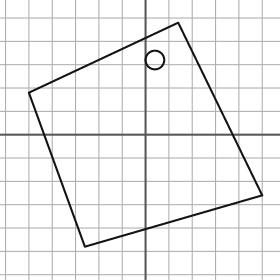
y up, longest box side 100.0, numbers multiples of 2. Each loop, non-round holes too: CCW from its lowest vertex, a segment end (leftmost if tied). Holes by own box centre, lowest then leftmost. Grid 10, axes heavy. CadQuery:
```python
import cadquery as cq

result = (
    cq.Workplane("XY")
    .moveTo(-26.0, -48.0)
    .lineTo(50.0, -26.0)
    .lineTo(14.0, 48.0)
    .lineTo(-50.0, 18.0)
    .close()
    .moveTo(4.0, 32.0)
    .circle(4.0)
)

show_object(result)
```